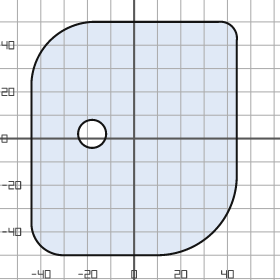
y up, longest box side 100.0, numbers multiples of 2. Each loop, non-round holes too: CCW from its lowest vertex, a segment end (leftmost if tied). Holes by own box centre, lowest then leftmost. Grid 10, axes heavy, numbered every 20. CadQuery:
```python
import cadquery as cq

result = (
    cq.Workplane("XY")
    .moveTo(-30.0, -50.0)
    .lineTo(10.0, -50.0)
    .threePointArc((34.0, -40.0), (44.0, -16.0))
    .lineTo(44.0, 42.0)
    .threePointArc((42.0, 48.0), (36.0, 50.0))
    .lineTo(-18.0, 50.0)
    .threePointArc((-36.0, 42.0), (-44.0, 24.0))
    .lineTo(-44.0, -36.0)
    .threePointArc((-40.0, -46.0), (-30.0, -50.0))
    .close()
    .moveTo(-18.0, 2.0)
    .circle(6.0)
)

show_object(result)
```